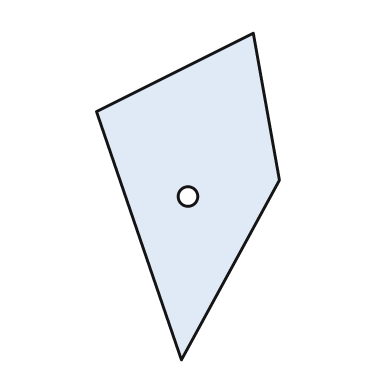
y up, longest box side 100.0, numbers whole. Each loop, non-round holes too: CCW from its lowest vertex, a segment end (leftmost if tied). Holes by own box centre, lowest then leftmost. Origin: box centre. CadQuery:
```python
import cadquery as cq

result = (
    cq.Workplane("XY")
    .moveTo(-2.0, -50.0)
    .lineTo(28.0, 5.0)
    .lineTo(20.0, 50.0)
    .lineTo(-28.0, 26.0)
    .close()
    .moveTo(0.0, 0.0)
    .circle(3.0)
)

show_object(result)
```